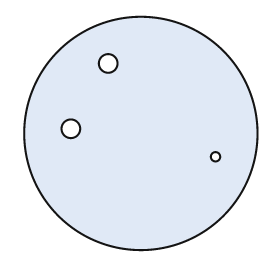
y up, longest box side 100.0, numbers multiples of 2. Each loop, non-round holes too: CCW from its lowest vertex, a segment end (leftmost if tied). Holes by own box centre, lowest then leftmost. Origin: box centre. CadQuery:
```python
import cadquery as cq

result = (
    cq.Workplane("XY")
    .moveTo(0.0, 0.0)
    .circle(50.0)
    .moveTo(32.0, -10.0)
    .circle(2.0)
    .moveTo(-30.0, 2.0)
    .circle(4.0)
    .moveTo(-14.0, 30.0)
    .circle(4.0)
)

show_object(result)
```